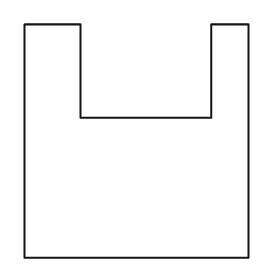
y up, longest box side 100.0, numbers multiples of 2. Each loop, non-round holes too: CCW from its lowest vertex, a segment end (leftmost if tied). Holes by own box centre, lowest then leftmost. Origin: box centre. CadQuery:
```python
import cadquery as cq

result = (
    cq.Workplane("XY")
    .moveTo(-48.0, -50.0)
    .lineTo(48.0, -50.0)
    .lineTo(48.0, 50.0)
    .lineTo(32.0, 50.0)
    .lineTo(32.0, 10.0)
    .lineTo(-24.0, 10.0)
    .lineTo(-24.0, 50.0)
    .lineTo(-48.0, 50.0)
    .close()
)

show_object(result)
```